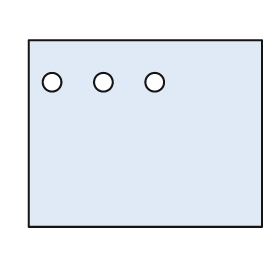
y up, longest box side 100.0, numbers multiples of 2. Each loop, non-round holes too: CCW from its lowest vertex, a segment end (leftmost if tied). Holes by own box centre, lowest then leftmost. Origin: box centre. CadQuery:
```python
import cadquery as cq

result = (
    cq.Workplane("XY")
    .moveTo(-50.0, -40.0)
    .lineTo(50.0, -40.0)
    .lineTo(50.0, 40.0)
    .lineTo(-50.0, 40.0)
    .close()
    .moveTo(-40.0, 22.0)
    .circle(4.0)
    .moveTo(-18.0, 22.0)
    .circle(4.0)
    .moveTo(4.0, 22.0)
    .circle(4.0)
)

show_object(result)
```